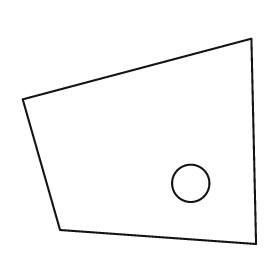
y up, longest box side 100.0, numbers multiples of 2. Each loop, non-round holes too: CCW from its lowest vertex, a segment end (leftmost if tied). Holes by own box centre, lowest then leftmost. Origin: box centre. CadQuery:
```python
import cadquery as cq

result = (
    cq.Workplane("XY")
    .moveTo(50.0, -44.0)
    .lineTo(48.0, 44.0)
    .lineTo(-50.0, 18.0)
    .lineTo(-34.0, -38.0)
    .close()
    .moveTo(22.0, -18.0)
    .circle(8.0)
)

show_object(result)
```